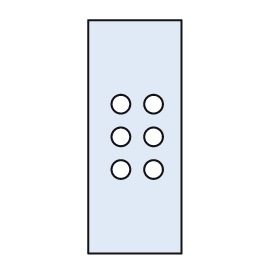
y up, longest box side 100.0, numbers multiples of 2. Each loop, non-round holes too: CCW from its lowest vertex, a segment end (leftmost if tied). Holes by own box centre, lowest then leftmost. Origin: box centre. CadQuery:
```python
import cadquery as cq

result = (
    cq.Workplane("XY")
    .moveTo(-20.0, -50.0)
    .lineTo(20.0, -50.0)
    .lineTo(20.0, 50.0)
    .lineTo(-20.0, 50.0)
    .close()
    .moveTo(-6.0, -14.0)
    .circle(4.0)
    .moveTo(8.0, -14.0)
    .circle(4.0)
    .moveTo(-6.0, 0.0)
    .circle(4.0)
    .moveTo(8.0, 0.0)
    .circle(4.0)
    .moveTo(-6.0, 14.0)
    .circle(4.0)
    .moveTo(8.0, 14.0)
    .circle(4.0)
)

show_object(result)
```